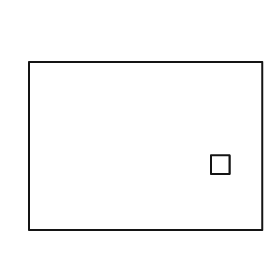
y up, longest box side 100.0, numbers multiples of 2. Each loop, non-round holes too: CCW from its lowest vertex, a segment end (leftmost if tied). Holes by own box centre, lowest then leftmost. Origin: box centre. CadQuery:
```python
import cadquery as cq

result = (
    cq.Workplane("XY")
    .moveTo(-50.0, -36.0)
    .lineTo(50.0, -36.0)
    .lineTo(50.0, 36.0)
    .lineTo(-50.0, 36.0)
    .close()
    .moveTo(28.0, -12.0)
    .lineTo(36.0, -12.0)
    .lineTo(36.0, -4.0)
    .lineTo(28.0, -4.0)
    .close()
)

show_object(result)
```